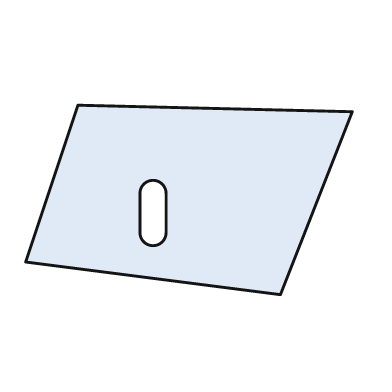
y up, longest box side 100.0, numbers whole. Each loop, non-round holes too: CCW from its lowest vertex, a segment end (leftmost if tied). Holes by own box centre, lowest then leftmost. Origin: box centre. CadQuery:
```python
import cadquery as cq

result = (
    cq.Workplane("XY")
    .moveTo(28.0, -29.0)
    .lineTo(50.0, 27.0)
    .lineTo(-34.0, 29.0)
    .lineTo(-50.0, -19.0)
    .close()
    .moveTo(-15.0, -10.0)
    .threePointArc((-11.0, -14.0), (-7.0, -10.0))
    .lineTo(-7.0, 2.0)
    .threePointArc((-11.0, 6.0), (-15.0, 2.0))
    .close()
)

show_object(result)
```